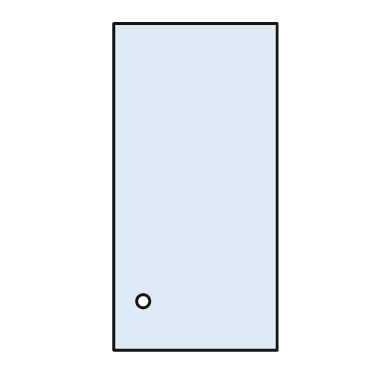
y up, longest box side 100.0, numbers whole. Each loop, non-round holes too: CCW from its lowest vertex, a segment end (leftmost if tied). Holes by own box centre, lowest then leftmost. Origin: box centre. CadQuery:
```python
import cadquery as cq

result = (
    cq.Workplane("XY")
    .moveTo(-25.0, -50.0)
    .lineTo(25.0, -50.0)
    .lineTo(25.0, 50.0)
    .lineTo(-25.0, 50.0)
    .close()
    .moveTo(-16.0, -35.0)
    .circle(2.0)
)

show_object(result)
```